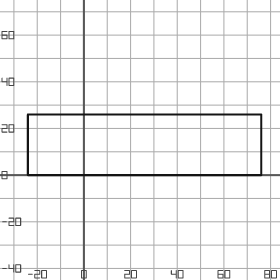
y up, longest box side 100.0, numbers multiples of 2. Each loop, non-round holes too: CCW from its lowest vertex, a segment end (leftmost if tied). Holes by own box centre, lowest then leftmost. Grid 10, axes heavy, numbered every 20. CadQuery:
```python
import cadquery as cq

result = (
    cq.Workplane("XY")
    .moveTo(-24.0, 0.0)
    .lineTo(76.0, 0.0)
    .lineTo(76.0, 26.0)
    .lineTo(-24.0, 26.0)
    .close()
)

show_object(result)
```